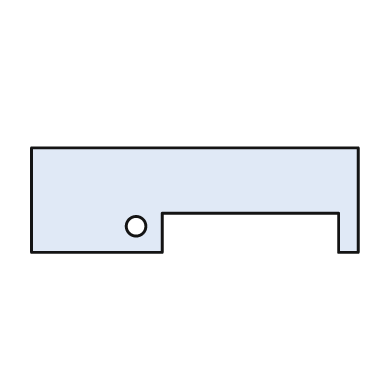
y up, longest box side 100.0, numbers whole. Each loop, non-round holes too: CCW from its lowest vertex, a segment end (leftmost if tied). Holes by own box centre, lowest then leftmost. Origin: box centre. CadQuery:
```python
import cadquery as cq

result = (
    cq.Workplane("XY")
    .moveTo(-50.0, -16.0)
    .lineTo(-10.0, -16.0)
    .lineTo(-10.0, -4.0)
    .lineTo(44.0, -4.0)
    .lineTo(44.0, -16.0)
    .lineTo(50.0, -16.0)
    .lineTo(50.0, 16.0)
    .lineTo(-50.0, 16.0)
    .close()
    .moveTo(-18.0, -8.0)
    .circle(3.0)
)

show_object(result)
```